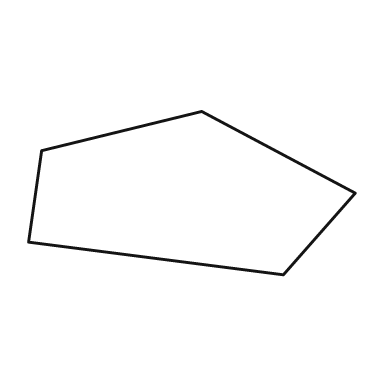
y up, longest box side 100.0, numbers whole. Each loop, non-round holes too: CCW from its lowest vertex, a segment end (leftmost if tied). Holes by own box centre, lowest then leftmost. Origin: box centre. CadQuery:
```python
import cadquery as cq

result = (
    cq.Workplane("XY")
    .moveTo(28.0, -25.0)
    .lineTo(50.0, 0.0)
    .lineTo(3.0, 25.0)
    .lineTo(-46.0, 13.0)
    .lineTo(-50.0, -15.0)
    .close()
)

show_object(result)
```